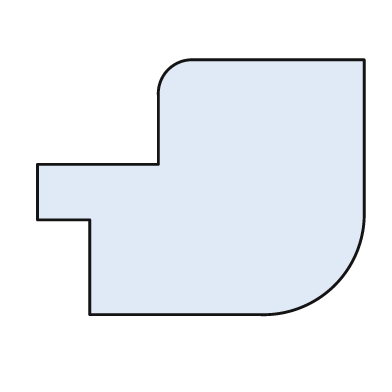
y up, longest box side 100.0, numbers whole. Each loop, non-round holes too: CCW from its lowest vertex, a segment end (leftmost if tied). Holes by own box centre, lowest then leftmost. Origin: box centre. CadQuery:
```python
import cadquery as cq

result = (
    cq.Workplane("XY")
    .moveTo(-34.0, -39.0)
    .lineTo(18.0, -39.0)
    .threePointArc((41.0, -30.0), (50.0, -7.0))
    .lineTo(50.0, 39.0)
    .lineTo(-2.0, 39.0)
    .threePointArc((-10.0, 36.0), (-13.0, 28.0))
    .lineTo(-13.0, 7.0)
    .lineTo(-50.0, 7.0)
    .lineTo(-50.0, -10.0)
    .lineTo(-34.0, -10.0)
    .close()
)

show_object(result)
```